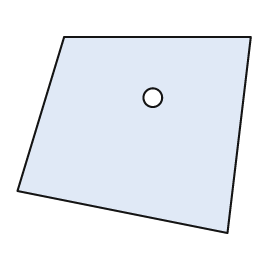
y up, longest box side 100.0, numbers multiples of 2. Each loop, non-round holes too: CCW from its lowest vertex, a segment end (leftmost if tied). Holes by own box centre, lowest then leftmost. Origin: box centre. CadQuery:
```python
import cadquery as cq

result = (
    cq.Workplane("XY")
    .moveTo(40.0, -42.0)
    .lineTo(50.0, 42.0)
    .lineTo(-30.0, 42.0)
    .lineTo(-50.0, -24.0)
    .close()
    .moveTo(8.0, 16.0)
    .circle(4.0)
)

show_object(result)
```